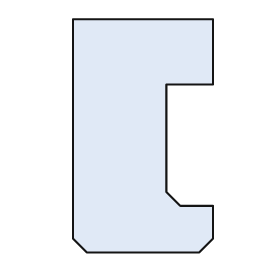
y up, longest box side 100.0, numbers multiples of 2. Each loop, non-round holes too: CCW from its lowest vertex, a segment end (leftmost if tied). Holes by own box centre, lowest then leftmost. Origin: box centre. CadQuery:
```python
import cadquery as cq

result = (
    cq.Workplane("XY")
    .moveTo(-24.0, -50.0)
    .lineTo(24.0, -50.0)
    .lineTo(30.0, -44.0)
    .lineTo(30.0, -30.0)
    .lineTo(16.0, -30.0)
    .lineTo(10.0, -24.0)
    .lineTo(10.0, 22.0)
    .lineTo(30.0, 22.0)
    .lineTo(30.0, 50.0)
    .lineTo(-30.0, 50.0)
    .lineTo(-30.0, -44.0)
    .close()
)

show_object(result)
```